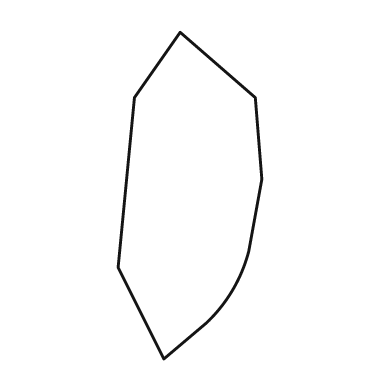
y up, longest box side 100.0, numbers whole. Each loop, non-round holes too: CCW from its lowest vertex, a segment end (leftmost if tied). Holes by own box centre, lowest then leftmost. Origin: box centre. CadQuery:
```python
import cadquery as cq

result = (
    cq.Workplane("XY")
    .moveTo(-8.0, -50.0)
    .lineTo(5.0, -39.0)
    .threePointArc((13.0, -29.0), (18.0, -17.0))
    .lineTo(22.0, 5.0)
    .lineTo(20.0, 30.0)
    .lineTo(-3.0, 50.0)
    .lineTo(-17.0, 30.0)
    .lineTo(-22.0, -22.0)
    .close()
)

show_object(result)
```